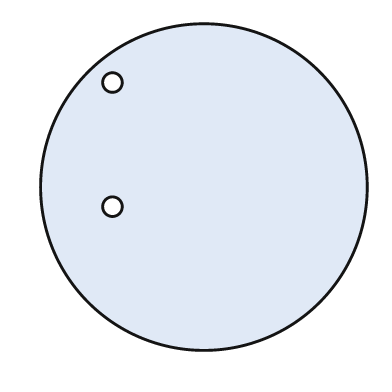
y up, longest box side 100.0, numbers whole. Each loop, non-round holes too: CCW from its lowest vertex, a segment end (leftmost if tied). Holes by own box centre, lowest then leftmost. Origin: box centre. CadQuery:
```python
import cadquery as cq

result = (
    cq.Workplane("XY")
    .moveTo(0.0, 0.0)
    .circle(50.0)
    .moveTo(-28.0, -6.0)
    .circle(3.0)
    .moveTo(-28.0, 32.0)
    .circle(3.0)
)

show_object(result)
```